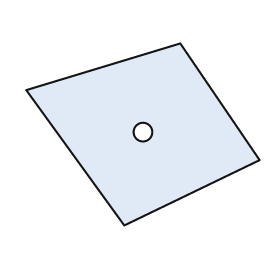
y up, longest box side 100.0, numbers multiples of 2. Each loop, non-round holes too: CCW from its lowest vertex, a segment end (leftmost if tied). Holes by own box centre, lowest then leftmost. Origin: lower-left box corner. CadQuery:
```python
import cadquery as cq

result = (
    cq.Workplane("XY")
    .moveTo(42.0, 0.0)
    .lineTo(100.0, 28.0)
    .lineTo(66.0, 78.0)
    .lineTo(0.0, 58.0)
    .close()
    .moveTo(50.0, 40.0)
    .circle(4.0)
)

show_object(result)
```